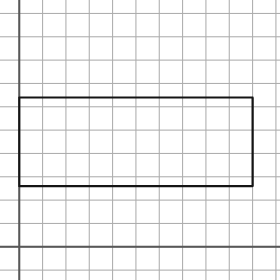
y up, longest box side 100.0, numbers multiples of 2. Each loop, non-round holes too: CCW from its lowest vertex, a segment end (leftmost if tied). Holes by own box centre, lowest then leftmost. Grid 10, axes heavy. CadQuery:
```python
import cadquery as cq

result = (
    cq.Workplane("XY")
    .moveTo(0.0, 26.0)
    .lineTo(100.0, 26.0)
    .lineTo(100.0, 64.0)
    .lineTo(0.0, 64.0)
    .close()
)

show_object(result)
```